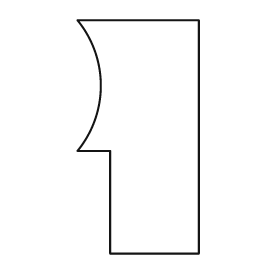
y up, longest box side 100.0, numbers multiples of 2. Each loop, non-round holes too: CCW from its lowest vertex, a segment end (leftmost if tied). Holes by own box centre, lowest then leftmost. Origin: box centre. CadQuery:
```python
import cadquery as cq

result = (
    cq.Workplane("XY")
    .moveTo(-12.0, -50.0)
    .lineTo(26.0, -50.0)
    .lineTo(26.0, 50.0)
    .lineTo(-26.0, 50.0)
    .threePointArc((-16.0, 22.0), (-26.0, -6.0))
    .lineTo(-12.0, -6.0)
    .close()
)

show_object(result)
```